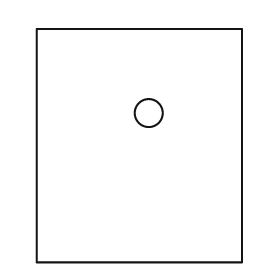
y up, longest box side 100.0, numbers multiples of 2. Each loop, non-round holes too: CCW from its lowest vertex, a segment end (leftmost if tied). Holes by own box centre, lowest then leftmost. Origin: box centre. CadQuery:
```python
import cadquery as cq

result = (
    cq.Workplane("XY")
    .moveTo(-44.0, -50.0)
    .lineTo(44.0, -50.0)
    .lineTo(44.0, 50.0)
    .lineTo(-44.0, 50.0)
    .close()
    .moveTo(4.0, 14.0)
    .circle(6.0)
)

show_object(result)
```